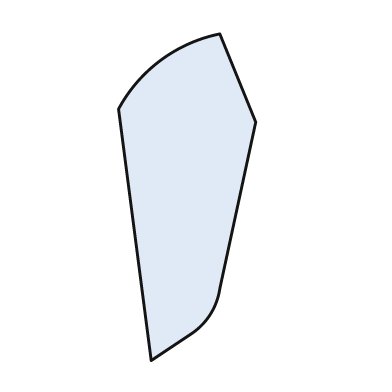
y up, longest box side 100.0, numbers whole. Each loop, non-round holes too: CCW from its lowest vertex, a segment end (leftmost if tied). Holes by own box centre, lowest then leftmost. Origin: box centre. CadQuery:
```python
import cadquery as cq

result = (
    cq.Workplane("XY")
    .moveTo(-11.0, -50.0)
    .lineTo(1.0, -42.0)
    .threePointArc((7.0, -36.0), (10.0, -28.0))
    .lineTo(21.0, 23.0)
    .lineTo(10.0, 50.0)
    .threePointArc((-8.0, 42.0), (-21.0, 27.0))
    .close()
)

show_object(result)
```